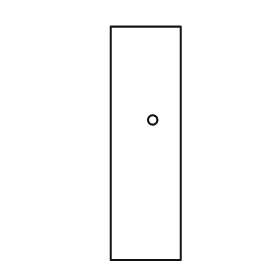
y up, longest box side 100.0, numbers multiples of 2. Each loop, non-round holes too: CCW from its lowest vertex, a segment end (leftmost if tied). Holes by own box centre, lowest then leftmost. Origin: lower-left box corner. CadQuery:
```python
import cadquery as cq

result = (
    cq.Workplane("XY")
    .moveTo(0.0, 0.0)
    .lineTo(30.0, 0.0)
    .lineTo(30.0, 100.0)
    .lineTo(0.0, 100.0)
    .close()
    .moveTo(18.0, 60.0)
    .circle(2.0)
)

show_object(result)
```